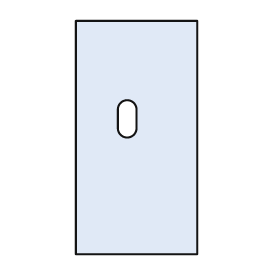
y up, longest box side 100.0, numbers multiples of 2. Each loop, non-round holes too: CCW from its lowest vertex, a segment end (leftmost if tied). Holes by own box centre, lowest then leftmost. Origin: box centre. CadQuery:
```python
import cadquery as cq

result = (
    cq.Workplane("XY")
    .moveTo(-26.0, -50.0)
    .lineTo(26.0, -50.0)
    .lineTo(26.0, 50.0)
    .lineTo(-26.0, 50.0)
    .close()
    .moveTo(-8.0, 4.0)
    .threePointArc((-4.0, 0.0), (0.0, 4.0))
    .lineTo(0.0, 12.0)
    .threePointArc((-4.0, 16.0), (-8.0, 12.0))
    .close()
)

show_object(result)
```